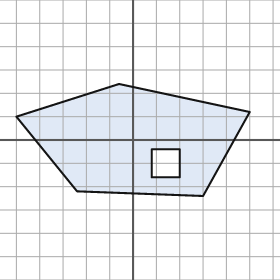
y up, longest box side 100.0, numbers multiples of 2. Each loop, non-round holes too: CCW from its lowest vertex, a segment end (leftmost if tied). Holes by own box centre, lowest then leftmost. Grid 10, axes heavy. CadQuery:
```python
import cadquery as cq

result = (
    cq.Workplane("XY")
    .moveTo(30.0, -24.0)
    .lineTo(50.0, 12.0)
    .lineTo(-6.0, 24.0)
    .lineTo(-50.0, 10.0)
    .lineTo(-24.0, -22.0)
    .close()
    .moveTo(8.0, -16.0)
    .lineTo(20.0, -16.0)
    .lineTo(20.0, -4.0)
    .lineTo(8.0, -4.0)
    .close()
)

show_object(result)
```